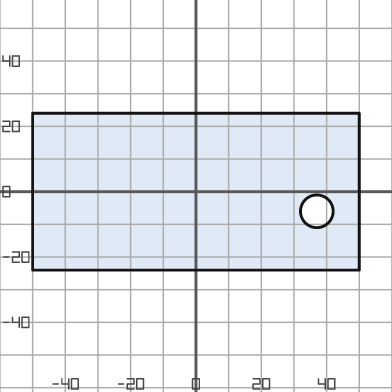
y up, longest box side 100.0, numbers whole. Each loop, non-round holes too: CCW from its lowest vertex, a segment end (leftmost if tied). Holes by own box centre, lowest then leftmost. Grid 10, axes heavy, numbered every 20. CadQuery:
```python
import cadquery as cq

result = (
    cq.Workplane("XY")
    .moveTo(-50.0, -24.0)
    .lineTo(50.0, -24.0)
    .lineTo(50.0, 24.0)
    .lineTo(-50.0, 24.0)
    .close()
    .moveTo(37.0, -6.0)
    .circle(5.0)
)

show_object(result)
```